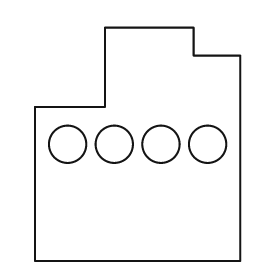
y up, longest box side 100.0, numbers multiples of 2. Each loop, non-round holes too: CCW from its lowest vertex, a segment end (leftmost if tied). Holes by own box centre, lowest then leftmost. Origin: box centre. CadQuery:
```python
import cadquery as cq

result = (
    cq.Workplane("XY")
    .moveTo(-44.0, -50.0)
    .lineTo(44.0, -50.0)
    .lineTo(44.0, 38.0)
    .lineTo(24.0, 38.0)
    .lineTo(24.0, 50.0)
    .lineTo(-14.0, 50.0)
    .lineTo(-14.0, 16.0)
    .lineTo(-44.0, 16.0)
    .close()
    .moveTo(-30.0, 0.0)
    .circle(8.0)
    .moveTo(-10.0, 0.0)
    .circle(8.0)
    .moveTo(10.0, 0.0)
    .circle(8.0)
    .moveTo(30.0, 0.0)
    .circle(8.0)
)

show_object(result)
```